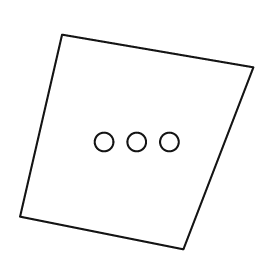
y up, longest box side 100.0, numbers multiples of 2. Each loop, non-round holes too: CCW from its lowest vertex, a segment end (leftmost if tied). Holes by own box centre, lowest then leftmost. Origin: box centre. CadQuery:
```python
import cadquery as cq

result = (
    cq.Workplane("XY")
    .moveTo(20.0, -46.0)
    .lineTo(50.0, 32.0)
    .lineTo(-32.0, 46.0)
    .lineTo(-50.0, -32.0)
    .close()
    .moveTo(-14.0, 0.0)
    .circle(4.0)
    .moveTo(0.0, 0.0)
    .circle(4.0)
    .moveTo(14.0, 0.0)
    .circle(4.0)
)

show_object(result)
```